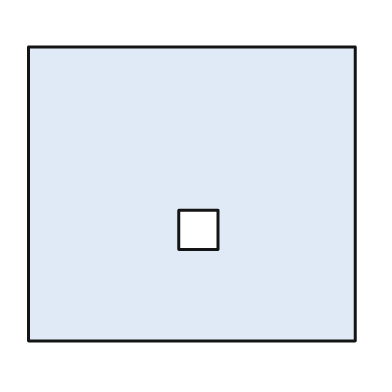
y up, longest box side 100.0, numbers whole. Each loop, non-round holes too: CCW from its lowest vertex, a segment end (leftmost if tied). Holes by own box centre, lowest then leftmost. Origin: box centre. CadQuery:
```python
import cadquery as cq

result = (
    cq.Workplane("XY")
    .moveTo(-50.0, -45.0)
    .lineTo(50.0, -45.0)
    .lineTo(50.0, 45.0)
    .lineTo(-50.0, 45.0)
    .close()
    .moveTo(-4.0, -17.0)
    .lineTo(8.0, -17.0)
    .lineTo(8.0, -5.0)
    .lineTo(-4.0, -5.0)
    .close()
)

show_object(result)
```